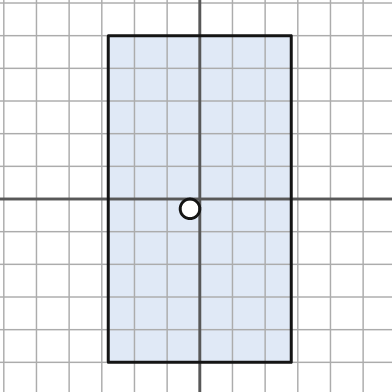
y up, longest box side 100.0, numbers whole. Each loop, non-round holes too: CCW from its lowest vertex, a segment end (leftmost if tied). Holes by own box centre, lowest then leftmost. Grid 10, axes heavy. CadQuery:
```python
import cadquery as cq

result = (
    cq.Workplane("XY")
    .moveTo(-28.0, -50.0)
    .lineTo(28.0, -50.0)
    .lineTo(28.0, 50.0)
    .lineTo(-28.0, 50.0)
    .close()
    .moveTo(-3.0, -3.0)
    .circle(3.0)
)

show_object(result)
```